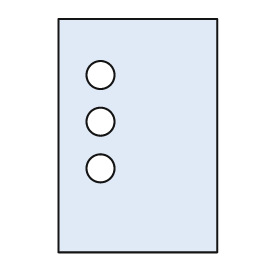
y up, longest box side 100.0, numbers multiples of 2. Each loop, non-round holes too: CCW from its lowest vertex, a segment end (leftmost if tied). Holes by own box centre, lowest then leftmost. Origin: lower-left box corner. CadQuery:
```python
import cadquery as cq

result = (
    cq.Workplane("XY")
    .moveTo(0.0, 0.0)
    .lineTo(68.0, 0.0)
    .lineTo(68.0, 100.0)
    .lineTo(0.0, 100.0)
    .close()
    .moveTo(18.0, 36.0)
    .circle(6.0)
    .moveTo(18.0, 56.0)
    .circle(6.0)
    .moveTo(18.0, 76.0)
    .circle(6.0)
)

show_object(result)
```